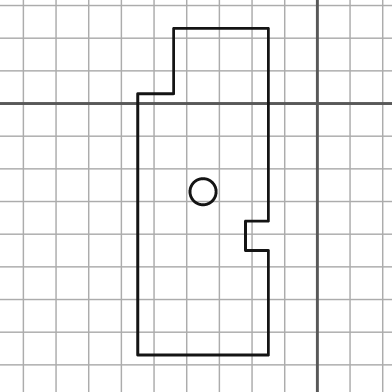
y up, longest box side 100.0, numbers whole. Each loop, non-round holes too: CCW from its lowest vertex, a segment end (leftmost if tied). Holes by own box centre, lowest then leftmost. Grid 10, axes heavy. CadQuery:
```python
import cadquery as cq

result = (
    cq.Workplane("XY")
    .moveTo(-55.0, -77.0)
    .lineTo(-15.0, -77.0)
    .lineTo(-15.0, -45.0)
    .lineTo(-22.0, -45.0)
    .lineTo(-22.0, -36.0)
    .lineTo(-15.0, -36.0)
    .lineTo(-15.0, 23.0)
    .lineTo(-44.0, 23.0)
    .lineTo(-44.0, 3.0)
    .lineTo(-55.0, 3.0)
    .close()
    .moveTo(-35.0, -27.0)
    .circle(4.0)
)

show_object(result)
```